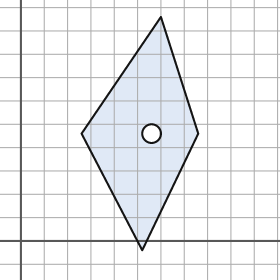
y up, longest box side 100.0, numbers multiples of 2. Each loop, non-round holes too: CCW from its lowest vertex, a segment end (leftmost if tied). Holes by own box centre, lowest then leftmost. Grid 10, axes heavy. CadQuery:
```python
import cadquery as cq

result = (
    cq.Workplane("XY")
    .moveTo(52.0, -4.0)
    .lineTo(76.0, 46.0)
    .lineTo(60.0, 96.0)
    .lineTo(26.0, 46.0)
    .close()
    .moveTo(56.0, 46.0)
    .circle(4.0)
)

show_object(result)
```